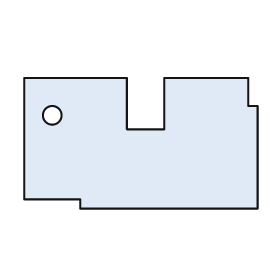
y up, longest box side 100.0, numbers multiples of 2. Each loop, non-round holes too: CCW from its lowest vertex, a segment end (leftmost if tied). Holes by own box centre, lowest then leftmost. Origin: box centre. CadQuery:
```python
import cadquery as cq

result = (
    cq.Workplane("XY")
    .moveTo(-26.0, -28.0)
    .lineTo(50.0, -28.0)
    .lineTo(50.0, 16.0)
    .lineTo(46.0, 16.0)
    .lineTo(46.0, 28.0)
    .lineTo(10.0, 28.0)
    .lineTo(10.0, 6.0)
    .lineTo(-6.0, 6.0)
    .lineTo(-6.0, 28.0)
    .lineTo(-50.0, 28.0)
    .lineTo(-50.0, -24.0)
    .lineTo(-26.0, -24.0)
    .close()
    .moveTo(-38.0, 12.0)
    .circle(4.0)
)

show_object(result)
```